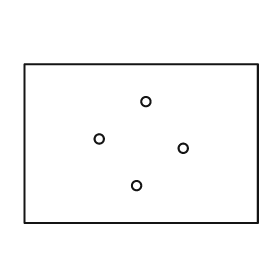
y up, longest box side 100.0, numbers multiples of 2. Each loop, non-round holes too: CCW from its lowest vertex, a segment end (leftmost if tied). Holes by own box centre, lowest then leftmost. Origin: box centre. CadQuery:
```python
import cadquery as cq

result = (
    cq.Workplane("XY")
    .moveTo(-50.0, -34.0)
    .lineTo(50.0, -34.0)
    .lineTo(50.0, 34.0)
    .lineTo(-50.0, 34.0)
    .close()
    .moveTo(-2.0, -18.0)
    .circle(2.0)
    .moveTo(18.0, -2.0)
    .circle(2.0)
    .moveTo(-18.0, 2.0)
    .circle(2.0)
    .moveTo(2.0, 18.0)
    .circle(2.0)
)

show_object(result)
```